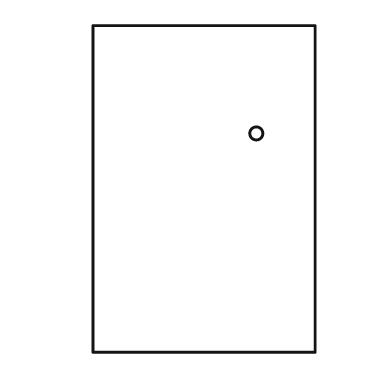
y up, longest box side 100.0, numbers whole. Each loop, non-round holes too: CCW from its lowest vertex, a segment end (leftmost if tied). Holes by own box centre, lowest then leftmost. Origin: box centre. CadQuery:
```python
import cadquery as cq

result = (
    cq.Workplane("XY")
    .moveTo(-34.0, -50.0)
    .lineTo(34.0, -50.0)
    .lineTo(34.0, 50.0)
    .lineTo(-34.0, 50.0)
    .close()
    .moveTo(16.0, 17.0)
    .circle(2.0)
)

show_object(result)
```